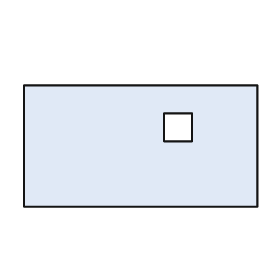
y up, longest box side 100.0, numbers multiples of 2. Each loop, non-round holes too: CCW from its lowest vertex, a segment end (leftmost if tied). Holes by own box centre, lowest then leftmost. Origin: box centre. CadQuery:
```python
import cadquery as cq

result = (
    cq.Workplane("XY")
    .moveTo(-50.0, -26.0)
    .lineTo(50.0, -26.0)
    .lineTo(50.0, 26.0)
    .lineTo(-50.0, 26.0)
    .close()
    .moveTo(10.0, 2.0)
    .lineTo(22.0, 2.0)
    .lineTo(22.0, 14.0)
    .lineTo(10.0, 14.0)
    .close()
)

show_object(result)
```